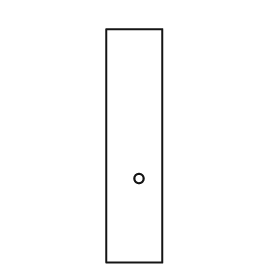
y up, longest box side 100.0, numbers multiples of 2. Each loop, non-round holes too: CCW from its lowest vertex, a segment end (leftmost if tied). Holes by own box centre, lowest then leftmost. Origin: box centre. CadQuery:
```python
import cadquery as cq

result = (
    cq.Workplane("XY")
    .moveTo(-12.0, -50.0)
    .lineTo(12.0, -50.0)
    .lineTo(12.0, 50.0)
    .lineTo(-12.0, 50.0)
    .close()
    .moveTo(2.0, -14.0)
    .circle(2.0)
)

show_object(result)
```